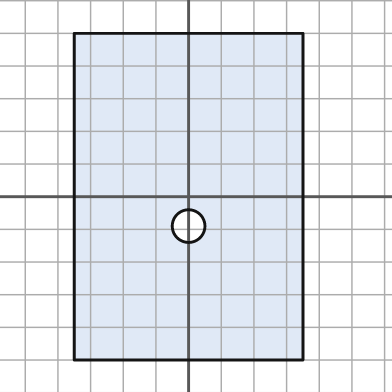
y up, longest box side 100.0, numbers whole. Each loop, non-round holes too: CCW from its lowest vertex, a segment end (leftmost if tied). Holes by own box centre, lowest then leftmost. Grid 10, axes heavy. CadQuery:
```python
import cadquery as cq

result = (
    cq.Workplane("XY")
    .moveTo(-35.0, -50.0)
    .lineTo(35.0, -50.0)
    .lineTo(35.0, 50.0)
    .lineTo(-35.0, 50.0)
    .close()
    .moveTo(0.0, -9.0)
    .circle(5.0)
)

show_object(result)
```